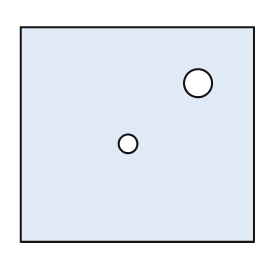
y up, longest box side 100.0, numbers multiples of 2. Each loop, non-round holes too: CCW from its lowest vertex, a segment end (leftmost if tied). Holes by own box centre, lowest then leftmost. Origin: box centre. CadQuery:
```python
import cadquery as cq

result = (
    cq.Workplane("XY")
    .moveTo(-50.0, -46.0)
    .lineTo(50.0, -46.0)
    .lineTo(50.0, 46.0)
    .lineTo(-50.0, 46.0)
    .close()
    .moveTo(-4.0, -4.0)
    .circle(4.0)
    .moveTo(26.0, 22.0)
    .circle(6.0)
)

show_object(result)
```